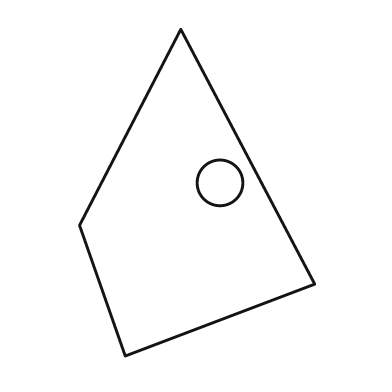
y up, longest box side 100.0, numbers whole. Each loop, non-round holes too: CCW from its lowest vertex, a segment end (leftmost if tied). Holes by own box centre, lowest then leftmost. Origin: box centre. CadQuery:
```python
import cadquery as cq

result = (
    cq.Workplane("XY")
    .moveTo(-22.0, -50.0)
    .lineTo(36.0, -28.0)
    .lineTo(-5.0, 50.0)
    .lineTo(-36.0, -10.0)
    .close()
    .moveTo(7.0, 3.0)
    .circle(7.0)
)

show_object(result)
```